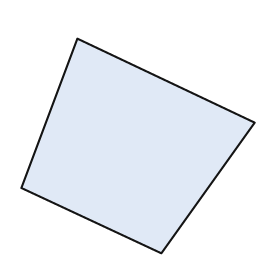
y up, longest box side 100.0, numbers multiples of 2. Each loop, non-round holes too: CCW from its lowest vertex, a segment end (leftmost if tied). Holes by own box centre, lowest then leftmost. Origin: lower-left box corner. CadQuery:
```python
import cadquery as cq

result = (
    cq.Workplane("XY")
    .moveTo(60.0, 0.0)
    .lineTo(100.0, 56.0)
    .lineTo(24.0, 92.0)
    .lineTo(0.0, 28.0)
    .close()
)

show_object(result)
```